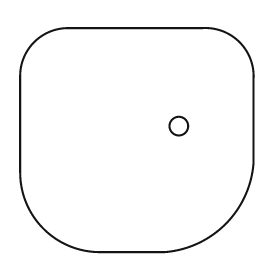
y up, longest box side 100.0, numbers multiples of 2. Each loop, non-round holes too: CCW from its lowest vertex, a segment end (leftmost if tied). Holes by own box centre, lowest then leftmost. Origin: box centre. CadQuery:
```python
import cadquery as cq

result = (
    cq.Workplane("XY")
    .moveTo(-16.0, -48.0)
    .lineTo(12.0, -48.0)
    .threePointArc((38.0, -36.0), (50.0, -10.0))
    .lineTo(50.0, 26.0)
    .threePointArc((44.0, 42.0), (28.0, 48.0))
    .lineTo(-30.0, 48.0)
    .threePointArc((-44.0, 42.0), (-50.0, 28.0))
    .lineTo(-50.0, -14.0)
    .threePointArc((-40.0, -38.0), (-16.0, -48.0))
    .close()
    .moveTo(18.0, 6.0)
    .circle(4.0)
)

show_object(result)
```